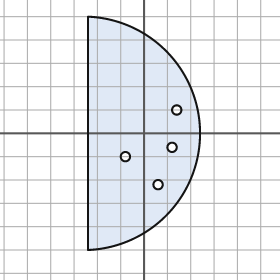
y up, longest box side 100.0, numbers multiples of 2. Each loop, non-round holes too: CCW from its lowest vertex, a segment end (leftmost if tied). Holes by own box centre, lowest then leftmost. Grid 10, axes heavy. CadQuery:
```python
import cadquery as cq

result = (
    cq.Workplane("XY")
    .moveTo(-24.0, -50.0)
    .threePointArc((24.0, 0.0), (-24.0, 50.0))
    .close()
    .moveTo(6.0, -22.0)
    .circle(2.0)
    .moveTo(-8.0, -10.0)
    .circle(2.0)
    .moveTo(12.0, -6.0)
    .circle(2.0)
    .moveTo(14.0, 10.0)
    .circle(2.0)
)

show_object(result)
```